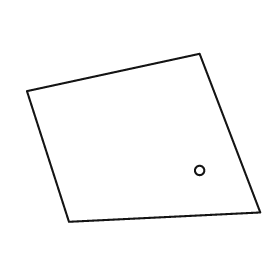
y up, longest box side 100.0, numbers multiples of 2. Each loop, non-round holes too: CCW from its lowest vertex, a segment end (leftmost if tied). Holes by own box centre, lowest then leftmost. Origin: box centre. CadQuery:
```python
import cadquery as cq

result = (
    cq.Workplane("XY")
    .moveTo(-32.0, -36.0)
    .lineTo(50.0, -32.0)
    .lineTo(24.0, 36.0)
    .lineTo(-50.0, 20.0)
    .close()
    .moveTo(24.0, -14.0)
    .circle(2.0)
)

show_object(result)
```